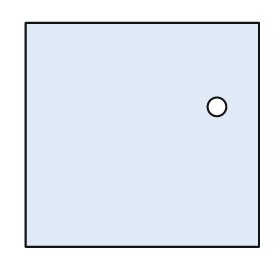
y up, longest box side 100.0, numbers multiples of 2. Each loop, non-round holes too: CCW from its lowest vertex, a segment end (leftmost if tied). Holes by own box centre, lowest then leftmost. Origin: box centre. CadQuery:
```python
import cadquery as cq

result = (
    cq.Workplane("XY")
    .moveTo(-50.0, -48.0)
    .lineTo(50.0, -48.0)
    .lineTo(50.0, 48.0)
    .lineTo(-50.0, 48.0)
    .close()
    .moveTo(32.0, 12.0)
    .circle(4.0)
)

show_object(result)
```